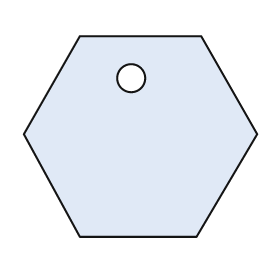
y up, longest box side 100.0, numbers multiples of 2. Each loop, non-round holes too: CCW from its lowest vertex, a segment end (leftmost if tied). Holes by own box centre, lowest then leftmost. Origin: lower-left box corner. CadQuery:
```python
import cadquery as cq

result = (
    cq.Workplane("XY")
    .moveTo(24.0, 0.0)
    .lineTo(74.0, 0.0)
    .lineTo(100.0, 44.0)
    .lineTo(76.0, 86.0)
    .lineTo(24.0, 86.0)
    .lineTo(0.0, 44.0)
    .close()
    .moveTo(46.0, 68.0)
    .circle(6.0)
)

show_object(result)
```